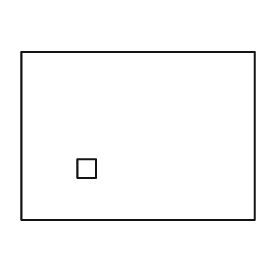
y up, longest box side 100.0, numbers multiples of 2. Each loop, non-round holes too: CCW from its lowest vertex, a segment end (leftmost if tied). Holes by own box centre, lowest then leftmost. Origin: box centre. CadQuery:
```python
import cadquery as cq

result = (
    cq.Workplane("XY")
    .moveTo(-50.0, -36.0)
    .lineTo(50.0, -36.0)
    .lineTo(50.0, 36.0)
    .lineTo(-50.0, 36.0)
    .close()
    .moveTo(-26.0, -18.0)
    .lineTo(-18.0, -18.0)
    .lineTo(-18.0, -10.0)
    .lineTo(-26.0, -10.0)
    .close()
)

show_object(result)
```